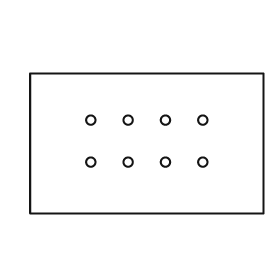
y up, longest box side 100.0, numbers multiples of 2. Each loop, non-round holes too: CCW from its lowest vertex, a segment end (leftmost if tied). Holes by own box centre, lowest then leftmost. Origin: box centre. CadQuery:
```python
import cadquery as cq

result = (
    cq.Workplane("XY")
    .moveTo(-50.0, -30.0)
    .lineTo(50.0, -30.0)
    .lineTo(50.0, 30.0)
    .lineTo(-50.0, 30.0)
    .close()
    .moveTo(-24.0, -8.0)
    .circle(2.0)
    .moveTo(-8.0, -8.0)
    .circle(2.0)
    .moveTo(8.0, -8.0)
    .circle(2.0)
    .moveTo(24.0, -8.0)
    .circle(2.0)
    .moveTo(-24.0, 10.0)
    .circle(2.0)
    .moveTo(-8.0, 10.0)
    .circle(2.0)
    .moveTo(8.0, 10.0)
    .circle(2.0)
    .moveTo(24.0, 10.0)
    .circle(2.0)
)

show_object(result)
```